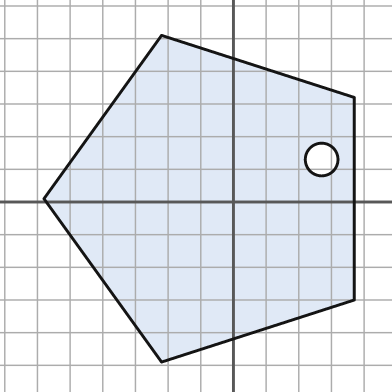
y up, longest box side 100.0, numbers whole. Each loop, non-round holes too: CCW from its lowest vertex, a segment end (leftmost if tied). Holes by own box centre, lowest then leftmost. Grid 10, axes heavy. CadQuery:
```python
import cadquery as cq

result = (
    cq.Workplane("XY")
    .moveTo(-22.0, -49.0)
    .lineTo(37.0, -30.0)
    .lineTo(37.0, 32.0)
    .lineTo(-22.0, 51.0)
    .lineTo(-58.0, 1.0)
    .close()
    .moveTo(27.0, 13.0)
    .circle(5.0)
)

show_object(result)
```